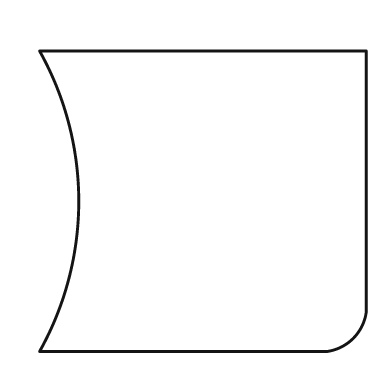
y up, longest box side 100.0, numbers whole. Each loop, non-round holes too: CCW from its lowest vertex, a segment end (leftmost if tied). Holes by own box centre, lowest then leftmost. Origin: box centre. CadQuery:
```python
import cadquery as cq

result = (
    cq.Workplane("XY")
    .moveTo(-50.0, -46.0)
    .lineTo(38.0, -46.0)
    .threePointArc((46.0, -42.0), (50.0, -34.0))
    .lineTo(50.0, 46.0)
    .lineTo(-50.0, 46.0)
    .threePointArc((-38.0, 0.0), (-50.0, -46.0))
    .close()
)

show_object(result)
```